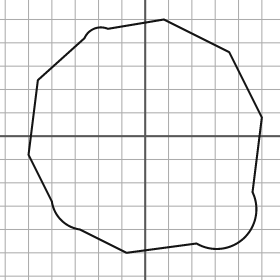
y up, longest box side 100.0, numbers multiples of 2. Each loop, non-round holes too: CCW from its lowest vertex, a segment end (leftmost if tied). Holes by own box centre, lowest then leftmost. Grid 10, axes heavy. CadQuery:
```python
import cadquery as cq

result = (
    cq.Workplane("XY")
    .moveTo(-8.0, -50.0)
    .lineTo(22.0, -46.0)
    .threePointArc((42.0, -44.0), (46.0, -24.0))
    .lineTo(50.0, 8.0)
    .lineTo(36.0, 36.0)
    .lineTo(8.0, 50.0)
    .lineTo(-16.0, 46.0)
    .threePointArc((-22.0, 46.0), (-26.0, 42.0))
    .lineTo(-46.0, 24.0)
    .lineTo(-50.0, -8.0)
    .lineTo(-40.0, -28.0)
    .threePointArc((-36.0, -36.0), (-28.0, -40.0))
    .close()
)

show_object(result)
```